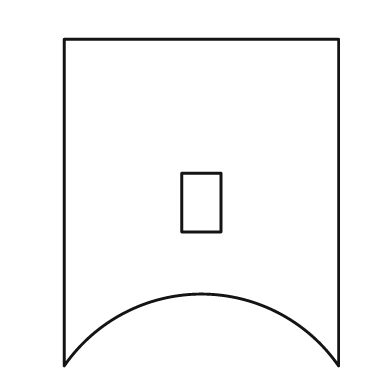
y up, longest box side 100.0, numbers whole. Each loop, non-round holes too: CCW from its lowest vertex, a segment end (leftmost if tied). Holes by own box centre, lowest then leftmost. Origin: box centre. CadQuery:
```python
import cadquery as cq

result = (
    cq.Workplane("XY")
    .moveTo(-42.0, -50.0)
    .threePointArc((0.0, -28.0), (42.0, -50.0))
    .lineTo(42.0, 50.0)
    .lineTo(-42.0, 50.0)
    .close()
    .moveTo(-6.0, -9.0)
    .lineTo(6.0, -9.0)
    .lineTo(6.0, 9.0)
    .lineTo(-6.0, 9.0)
    .close()
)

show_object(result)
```